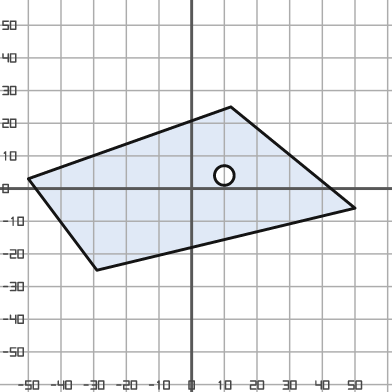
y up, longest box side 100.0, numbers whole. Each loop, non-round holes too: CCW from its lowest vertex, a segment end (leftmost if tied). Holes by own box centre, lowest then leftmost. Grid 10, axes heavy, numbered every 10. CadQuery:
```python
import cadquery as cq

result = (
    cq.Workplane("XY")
    .moveTo(-29.0, -25.0)
    .lineTo(50.0, -6.0)
    .lineTo(12.0, 25.0)
    .lineTo(-50.0, 3.0)
    .close()
    .moveTo(10.0, 4.0)
    .circle(3.0)
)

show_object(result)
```